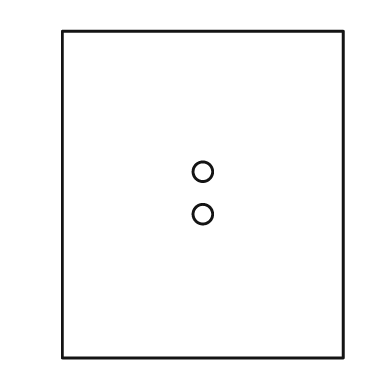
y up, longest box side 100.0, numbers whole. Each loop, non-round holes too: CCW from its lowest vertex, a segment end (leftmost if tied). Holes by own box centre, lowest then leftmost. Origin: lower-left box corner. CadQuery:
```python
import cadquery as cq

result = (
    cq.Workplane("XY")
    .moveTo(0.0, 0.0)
    .lineTo(86.0, 0.0)
    .lineTo(86.0, 100.0)
    .lineTo(0.0, 100.0)
    .close()
    .moveTo(43.0, 44.0)
    .circle(3.0)
    .moveTo(43.0, 57.0)
    .circle(3.0)
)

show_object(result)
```